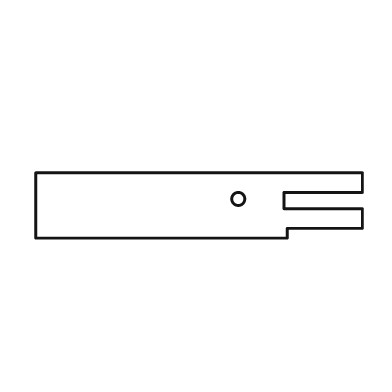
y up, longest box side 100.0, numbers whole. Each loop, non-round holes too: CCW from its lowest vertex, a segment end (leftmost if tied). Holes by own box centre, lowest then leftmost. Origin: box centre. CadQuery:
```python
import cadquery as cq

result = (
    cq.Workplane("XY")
    .moveTo(-50.0, -10.0)
    .lineTo(27.0, -10.0)
    .lineTo(27.0, -7.0)
    .lineTo(50.0, -7.0)
    .lineTo(50.0, -1.0)
    .lineTo(26.0, -1.0)
    .lineTo(26.0, 4.0)
    .lineTo(50.0, 4.0)
    .lineTo(50.0, 10.0)
    .lineTo(-50.0, 10.0)
    .close()
    .moveTo(12.0, 2.0)
    .circle(2.0)
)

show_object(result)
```